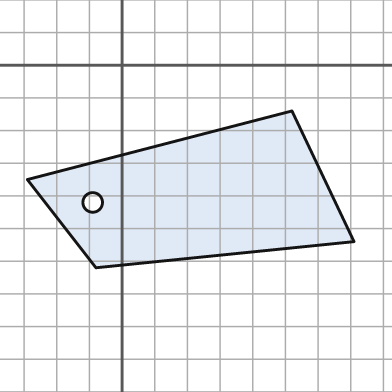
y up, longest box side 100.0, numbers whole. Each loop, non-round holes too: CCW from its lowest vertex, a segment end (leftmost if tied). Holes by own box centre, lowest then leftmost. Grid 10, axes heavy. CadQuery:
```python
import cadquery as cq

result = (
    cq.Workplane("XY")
    .moveTo(-8.0, -62.0)
    .lineTo(71.0, -54.0)
    .lineTo(52.0, -14.0)
    .lineTo(-29.0, -35.0)
    .close()
    .moveTo(-9.0, -42.0)
    .circle(3.0)
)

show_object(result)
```